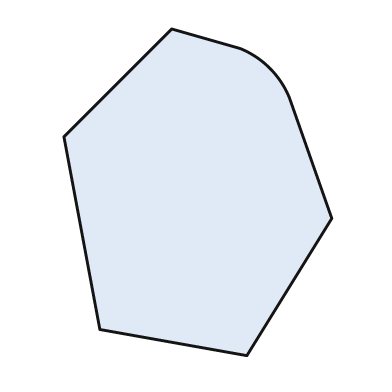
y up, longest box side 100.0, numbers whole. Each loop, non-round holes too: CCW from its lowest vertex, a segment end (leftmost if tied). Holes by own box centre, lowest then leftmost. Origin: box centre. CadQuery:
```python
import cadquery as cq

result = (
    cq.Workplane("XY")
    .moveTo(15.0, -50.0)
    .lineTo(41.0, -8.0)
    .lineTo(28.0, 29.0)
    .threePointArc((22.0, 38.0), (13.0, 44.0))
    .lineTo(-8.0, 50.0)
    .lineTo(-41.0, 17.0)
    .lineTo(-30.0, -42.0)
    .close()
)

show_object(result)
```